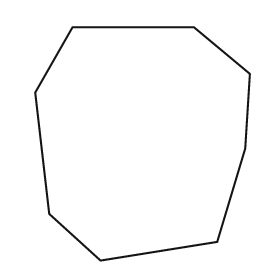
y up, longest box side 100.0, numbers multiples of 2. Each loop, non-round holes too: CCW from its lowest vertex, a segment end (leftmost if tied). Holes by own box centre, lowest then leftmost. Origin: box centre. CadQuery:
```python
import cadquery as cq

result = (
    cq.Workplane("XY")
    .moveTo(-18.0, -50.0)
    .lineTo(32.0, -42.0)
    .lineTo(44.0, -2.0)
    .lineTo(46.0, 30.0)
    .lineTo(22.0, 50.0)
    .lineTo(-30.0, 50.0)
    .lineTo(-46.0, 22.0)
    .lineTo(-40.0, -30.0)
    .close()
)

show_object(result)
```